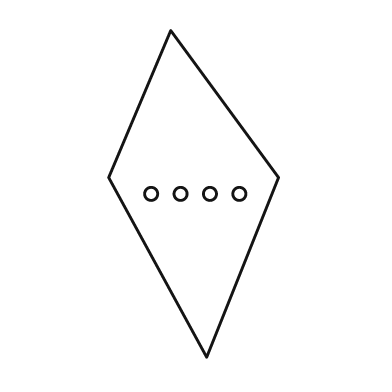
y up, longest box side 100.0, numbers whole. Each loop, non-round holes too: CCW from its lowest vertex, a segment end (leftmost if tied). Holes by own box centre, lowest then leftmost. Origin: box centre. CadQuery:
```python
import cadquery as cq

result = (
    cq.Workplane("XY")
    .moveTo(4.0, -50.0)
    .lineTo(26.0, 5.0)
    .lineTo(-7.0, 50.0)
    .lineTo(-26.0, 5.0)
    .close()
    .moveTo(-13.0, 0.0)
    .circle(2.0)
    .moveTo(-4.0, 0.0)
    .circle(2.0)
    .moveTo(5.0, 0.0)
    .circle(2.0)
    .moveTo(14.0, 0.0)
    .circle(2.0)
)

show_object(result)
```